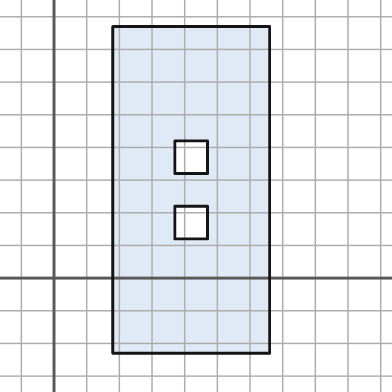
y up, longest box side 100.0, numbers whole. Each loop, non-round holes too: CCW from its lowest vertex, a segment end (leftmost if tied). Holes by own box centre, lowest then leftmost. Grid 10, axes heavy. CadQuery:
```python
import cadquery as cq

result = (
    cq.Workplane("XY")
    .moveTo(18.0, -23.0)
    .lineTo(66.0, -23.0)
    .lineTo(66.0, 77.0)
    .lineTo(18.0, 77.0)
    .close()
    .moveTo(37.0, 12.0)
    .lineTo(47.0, 12.0)
    .lineTo(47.0, 22.0)
    .lineTo(37.0, 22.0)
    .close()
    .moveTo(37.0, 32.0)
    .lineTo(47.0, 32.0)
    .lineTo(47.0, 42.0)
    .lineTo(37.0, 42.0)
    .close()
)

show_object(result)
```